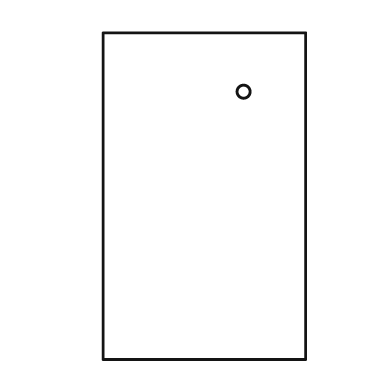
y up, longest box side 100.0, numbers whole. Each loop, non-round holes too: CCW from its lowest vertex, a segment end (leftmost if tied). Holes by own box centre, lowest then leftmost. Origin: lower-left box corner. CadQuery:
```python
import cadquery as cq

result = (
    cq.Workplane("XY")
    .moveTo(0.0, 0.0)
    .lineTo(62.0, 0.0)
    .lineTo(62.0, 100.0)
    .lineTo(0.0, 100.0)
    .close()
    .moveTo(43.0, 82.0)
    .circle(2.0)
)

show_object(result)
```